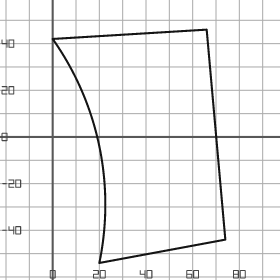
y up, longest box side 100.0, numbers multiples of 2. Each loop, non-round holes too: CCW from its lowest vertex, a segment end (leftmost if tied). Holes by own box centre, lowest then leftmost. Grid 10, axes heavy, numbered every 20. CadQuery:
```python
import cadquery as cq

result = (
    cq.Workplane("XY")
    .moveTo(20.0, -54.0)
    .lineTo(74.0, -44.0)
    .lineTo(66.0, 46.0)
    .lineTo(0.0, 42.0)
    .threePointArc((20.0, -4.0), (20.0, -54.0))
    .close()
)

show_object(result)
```